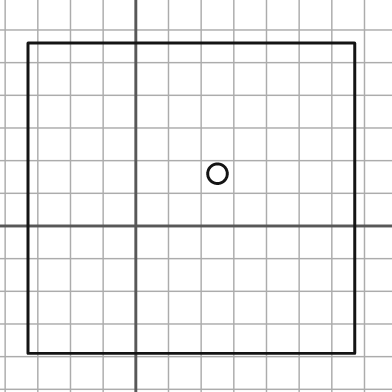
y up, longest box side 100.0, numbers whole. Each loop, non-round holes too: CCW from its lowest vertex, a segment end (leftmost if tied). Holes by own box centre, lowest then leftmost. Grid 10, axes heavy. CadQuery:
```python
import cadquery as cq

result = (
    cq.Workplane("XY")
    .moveTo(-33.0, -39.0)
    .lineTo(67.0, -39.0)
    .lineTo(67.0, 56.0)
    .lineTo(-33.0, 56.0)
    .close()
    .moveTo(25.0, 16.0)
    .circle(3.0)
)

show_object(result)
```